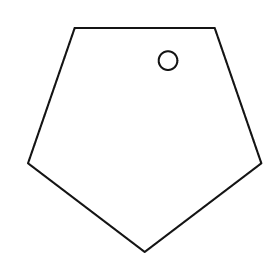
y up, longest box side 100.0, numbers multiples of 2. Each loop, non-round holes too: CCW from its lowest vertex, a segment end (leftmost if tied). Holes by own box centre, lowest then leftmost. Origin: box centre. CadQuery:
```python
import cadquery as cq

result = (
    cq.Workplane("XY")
    .moveTo(0.0, -48.0)
    .lineTo(50.0, -10.0)
    .lineTo(30.0, 48.0)
    .lineTo(-30.0, 48.0)
    .lineTo(-50.0, -10.0)
    .close()
    .moveTo(10.0, 34.0)
    .circle(4.0)
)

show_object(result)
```